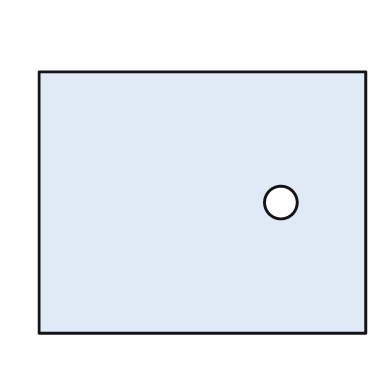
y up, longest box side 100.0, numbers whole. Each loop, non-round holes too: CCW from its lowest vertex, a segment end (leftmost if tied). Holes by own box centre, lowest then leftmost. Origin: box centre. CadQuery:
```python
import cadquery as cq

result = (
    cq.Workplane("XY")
    .moveTo(-50.0, -40.0)
    .lineTo(50.0, -40.0)
    .lineTo(50.0, 40.0)
    .lineTo(-50.0, 40.0)
    .close()
    .moveTo(24.0, 0.0)
    .circle(5.0)
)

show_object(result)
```